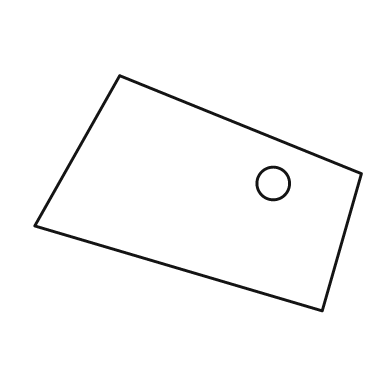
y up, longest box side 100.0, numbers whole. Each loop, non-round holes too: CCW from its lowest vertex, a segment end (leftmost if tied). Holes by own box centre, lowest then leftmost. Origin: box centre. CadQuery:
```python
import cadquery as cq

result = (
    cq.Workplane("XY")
    .moveTo(38.0, -36.0)
    .lineTo(50.0, 6.0)
    .lineTo(-24.0, 36.0)
    .lineTo(-50.0, -10.0)
    .close()
    .moveTo(23.0, 3.0)
    .circle(5.0)
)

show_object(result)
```